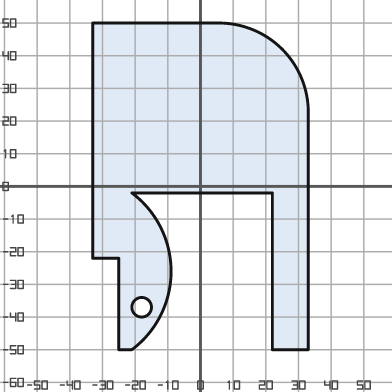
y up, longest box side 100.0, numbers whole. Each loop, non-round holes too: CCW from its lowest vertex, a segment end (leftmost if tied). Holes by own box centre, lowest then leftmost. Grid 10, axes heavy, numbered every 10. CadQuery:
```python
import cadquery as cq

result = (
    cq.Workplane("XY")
    .moveTo(-25.0, -50.0)
    .lineTo(-21.0, -50.0)
    .threePointArc((-9.0, -26.0), (-21.0, -2.0))
    .lineTo(22.0, -2.0)
    .lineTo(22.0, -50.0)
    .lineTo(33.0, -50.0)
    .lineTo(33.0, 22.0)
    .threePointArc((25.0, 42.0), (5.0, 50.0))
    .lineTo(-33.0, 50.0)
    .lineTo(-33.0, -22.0)
    .lineTo(-25.0, -22.0)
    .close()
    .moveTo(-18.0, -37.0)
    .circle(3.0)
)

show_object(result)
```